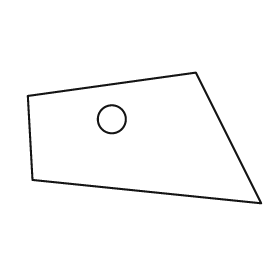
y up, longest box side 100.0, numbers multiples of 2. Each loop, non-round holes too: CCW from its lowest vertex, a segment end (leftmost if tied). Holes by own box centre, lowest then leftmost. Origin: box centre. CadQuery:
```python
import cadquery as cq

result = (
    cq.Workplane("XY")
    .moveTo(50.0, -28.0)
    .lineTo(22.0, 28.0)
    .lineTo(-50.0, 18.0)
    .lineTo(-48.0, -18.0)
    .close()
    .moveTo(-14.0, 8.0)
    .circle(6.0)
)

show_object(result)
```